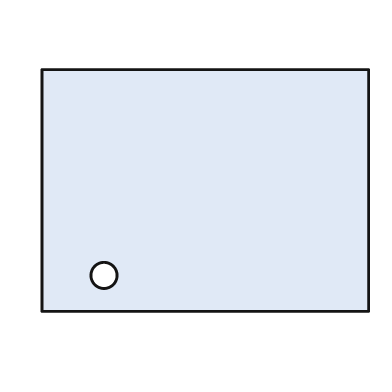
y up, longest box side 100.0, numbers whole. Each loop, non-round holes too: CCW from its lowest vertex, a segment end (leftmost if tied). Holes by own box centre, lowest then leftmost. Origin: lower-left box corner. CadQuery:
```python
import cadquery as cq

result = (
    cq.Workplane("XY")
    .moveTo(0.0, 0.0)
    .lineTo(100.0, 0.0)
    .lineTo(100.0, 74.0)
    .lineTo(0.0, 74.0)
    .close()
    .moveTo(19.0, 11.0)
    .circle(4.0)
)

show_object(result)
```